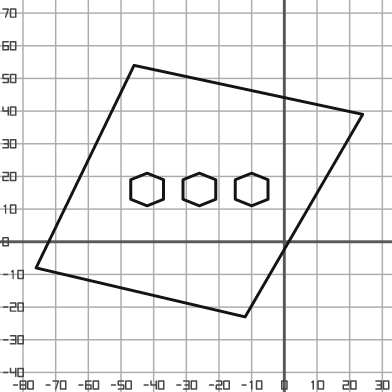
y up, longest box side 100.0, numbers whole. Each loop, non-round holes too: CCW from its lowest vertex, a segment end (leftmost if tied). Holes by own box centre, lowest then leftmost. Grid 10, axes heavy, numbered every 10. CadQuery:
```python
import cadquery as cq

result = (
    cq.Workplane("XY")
    .moveTo(-12.0, -23.0)
    .lineTo(24.0, 39.0)
    .lineTo(-46.0, 54.0)
    .lineTo(-76.0, -8.0)
    .close()
    .moveTo(-42.0, 11.0)
    .lineTo(-37.0, 13.0)
    .lineTo(-37.0, 19.0)
    .lineTo(-42.0, 21.0)
    .lineTo(-47.0, 19.0)
    .lineTo(-47.0, 13.0)
    .close()
    .moveTo(-26.0, 11.0)
    .lineTo(-21.0, 13.0)
    .lineTo(-21.0, 19.0)
    .lineTo(-26.0, 21.0)
    .lineTo(-31.0, 19.0)
    .lineTo(-31.0, 13.0)
    .close()
    .moveTo(-10.0, 11.0)
    .lineTo(-5.0, 13.0)
    .lineTo(-5.0, 19.0)
    .lineTo(-10.0, 21.0)
    .lineTo(-15.0, 19.0)
    .lineTo(-15.0, 13.0)
    .close()
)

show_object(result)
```